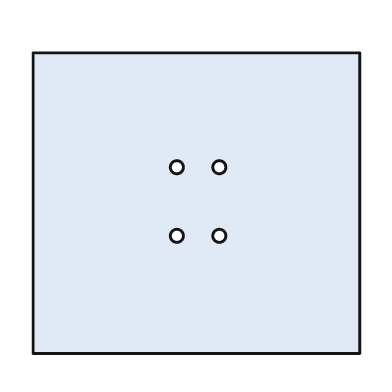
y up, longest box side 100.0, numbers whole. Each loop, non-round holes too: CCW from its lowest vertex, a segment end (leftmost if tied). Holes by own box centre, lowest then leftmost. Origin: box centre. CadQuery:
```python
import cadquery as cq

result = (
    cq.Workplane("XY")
    .moveTo(-50.0, -46.0)
    .lineTo(50.0, -46.0)
    .lineTo(50.0, 46.0)
    .lineTo(-50.0, 46.0)
    .close()
    .moveTo(-6.0, -10.0)
    .circle(2.0)
    .moveTo(7.0, -10.0)
    .circle(2.0)
    .moveTo(-6.0, 11.0)
    .circle(2.0)
    .moveTo(7.0, 11.0)
    .circle(2.0)
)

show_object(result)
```